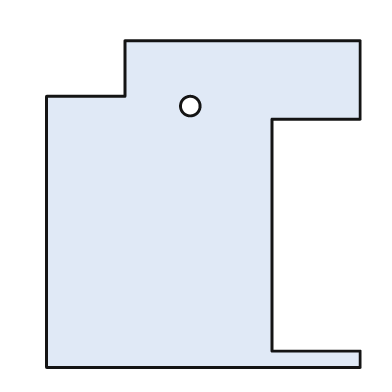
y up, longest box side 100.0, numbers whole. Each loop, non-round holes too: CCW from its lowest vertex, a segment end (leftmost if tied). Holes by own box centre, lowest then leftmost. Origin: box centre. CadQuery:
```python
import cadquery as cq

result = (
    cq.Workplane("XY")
    .moveTo(-48.0, -50.0)
    .lineTo(48.0, -50.0)
    .lineTo(48.0, -45.0)
    .lineTo(21.0, -45.0)
    .lineTo(21.0, 26.0)
    .lineTo(48.0, 26.0)
    .lineTo(48.0, 50.0)
    .lineTo(-24.0, 50.0)
    .lineTo(-24.0, 33.0)
    .lineTo(-48.0, 33.0)
    .close()
    .moveTo(-4.0, 30.0)
    .circle(3.0)
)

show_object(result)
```